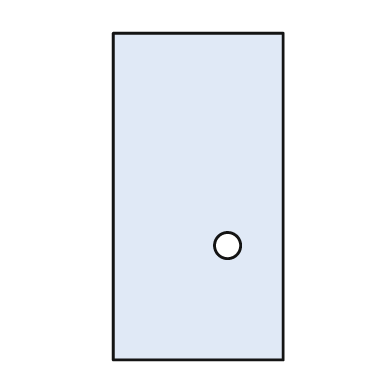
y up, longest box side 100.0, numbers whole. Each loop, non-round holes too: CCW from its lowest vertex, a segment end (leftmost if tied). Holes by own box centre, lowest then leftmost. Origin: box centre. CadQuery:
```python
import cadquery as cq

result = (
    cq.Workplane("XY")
    .moveTo(-26.0, -50.0)
    .lineTo(26.0, -50.0)
    .lineTo(26.0, 50.0)
    .lineTo(-26.0, 50.0)
    .close()
    .moveTo(9.0, -15.0)
    .circle(4.0)
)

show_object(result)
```